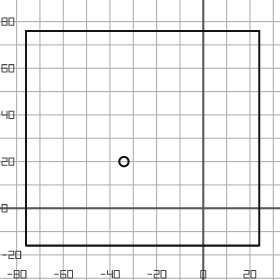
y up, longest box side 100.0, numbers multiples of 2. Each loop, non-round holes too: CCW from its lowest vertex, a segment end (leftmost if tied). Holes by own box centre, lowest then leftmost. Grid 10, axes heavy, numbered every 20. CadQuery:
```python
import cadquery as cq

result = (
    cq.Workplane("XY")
    .moveTo(-76.0, -16.0)
    .lineTo(24.0, -16.0)
    .lineTo(24.0, 76.0)
    .lineTo(-76.0, 76.0)
    .close()
    .moveTo(-34.0, 20.0)
    .circle(2.0)
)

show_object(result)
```